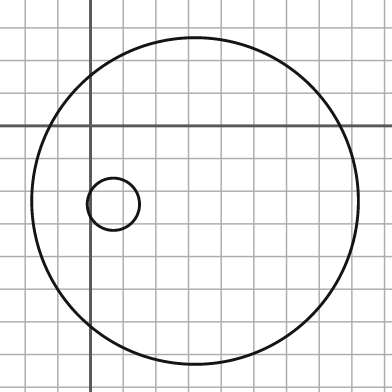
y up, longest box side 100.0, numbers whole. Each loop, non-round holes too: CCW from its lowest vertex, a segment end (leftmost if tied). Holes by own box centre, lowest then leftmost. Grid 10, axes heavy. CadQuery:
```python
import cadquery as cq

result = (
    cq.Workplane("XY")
    .moveTo(32.0, -23.0)
    .circle(50.0)
    .moveTo(7.0, -24.0)
    .circle(8.0)
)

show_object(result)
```